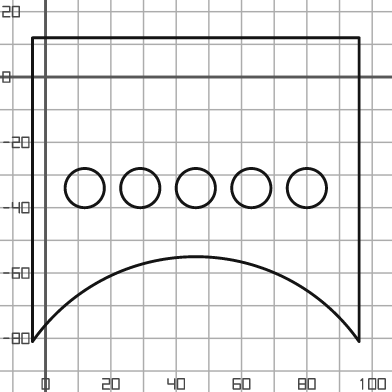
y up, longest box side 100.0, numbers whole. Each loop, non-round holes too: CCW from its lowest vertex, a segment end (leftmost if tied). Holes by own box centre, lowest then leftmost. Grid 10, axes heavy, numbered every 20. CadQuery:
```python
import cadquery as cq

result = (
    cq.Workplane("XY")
    .moveTo(-4.0, -81.0)
    .threePointArc((46.0, -55.0), (96.0, -81.0))
    .lineTo(96.0, 12.0)
    .lineTo(-4.0, 12.0)
    .close()
    .moveTo(12.0, -34.0)
    .circle(6.0)
    .moveTo(29.0, -34.0)
    .circle(6.0)
    .moveTo(46.0, -34.0)
    .circle(6.0)
    .moveTo(63.0, -34.0)
    .circle(6.0)
    .moveTo(80.0, -34.0)
    .circle(6.0)
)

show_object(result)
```